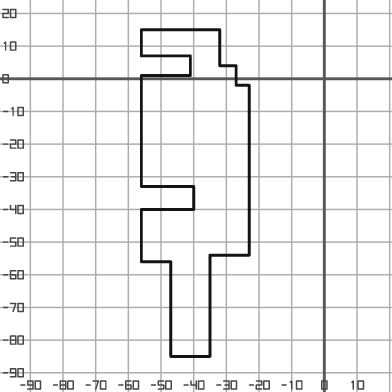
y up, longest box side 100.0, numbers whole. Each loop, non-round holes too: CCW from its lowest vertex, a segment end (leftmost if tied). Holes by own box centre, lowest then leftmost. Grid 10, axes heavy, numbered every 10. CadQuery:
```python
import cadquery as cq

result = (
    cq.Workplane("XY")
    .moveTo(-47.0, -85.0)
    .lineTo(-35.0, -85.0)
    .lineTo(-35.0, -54.0)
    .lineTo(-23.0, -54.0)
    .lineTo(-23.0, -2.0)
    .lineTo(-27.0, -2.0)
    .lineTo(-27.0, 4.0)
    .lineTo(-32.0, 4.0)
    .lineTo(-32.0, 15.0)
    .lineTo(-56.0, 15.0)
    .lineTo(-56.0, 7.0)
    .lineTo(-41.0, 7.0)
    .lineTo(-41.0, 1.0)
    .lineTo(-56.0, 1.0)
    .lineTo(-56.0, -33.0)
    .lineTo(-40.0, -33.0)
    .lineTo(-40.0, -40.0)
    .lineTo(-56.0, -40.0)
    .lineTo(-56.0, -56.0)
    .lineTo(-47.0, -56.0)
    .close()
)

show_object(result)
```